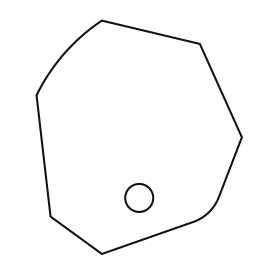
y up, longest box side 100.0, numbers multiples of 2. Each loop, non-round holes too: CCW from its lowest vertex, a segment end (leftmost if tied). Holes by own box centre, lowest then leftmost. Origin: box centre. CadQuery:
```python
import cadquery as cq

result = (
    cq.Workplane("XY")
    .moveTo(-16.0, -50.0)
    .lineTo(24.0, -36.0)
    .threePointArc((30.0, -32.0), (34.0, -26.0))
    .lineTo(44.0, 0.0)
    .lineTo(26.0, 40.0)
    .lineTo(-16.0, 50.0)
    .threePointArc((-32.0, 36.0), (-44.0, 18.0))
    .lineTo(-38.0, -34.0)
    .close()
    .moveTo(0.0, -26.0)
    .circle(6.0)
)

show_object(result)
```